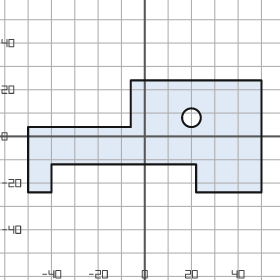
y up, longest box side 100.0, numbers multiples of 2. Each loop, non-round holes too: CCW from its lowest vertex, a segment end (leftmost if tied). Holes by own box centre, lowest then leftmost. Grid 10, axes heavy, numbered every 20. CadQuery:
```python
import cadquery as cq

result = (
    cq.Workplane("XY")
    .moveTo(-50.0, -24.0)
    .lineTo(-40.0, -24.0)
    .lineTo(-40.0, -12.0)
    .lineTo(22.0, -12.0)
    .lineTo(22.0, -24.0)
    .lineTo(50.0, -24.0)
    .lineTo(50.0, 24.0)
    .lineTo(-6.0, 24.0)
    .lineTo(-6.0, 4.0)
    .lineTo(-50.0, 4.0)
    .close()
    .moveTo(20.0, 8.0)
    .circle(4.0)
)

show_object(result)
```